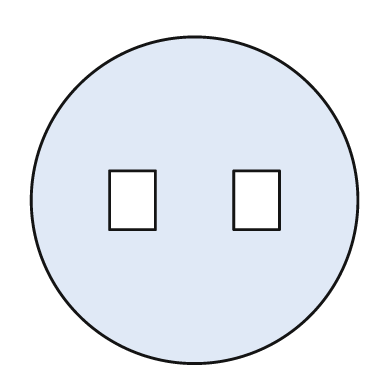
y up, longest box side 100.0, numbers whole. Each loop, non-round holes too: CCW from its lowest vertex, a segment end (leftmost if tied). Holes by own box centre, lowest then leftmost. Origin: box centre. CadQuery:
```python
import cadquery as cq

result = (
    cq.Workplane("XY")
    .moveTo(0.0, 0.0)
    .circle(50.0)
    .moveTo(-26.0, -9.0)
    .lineTo(-12.0, -9.0)
    .lineTo(-12.0, 9.0)
    .lineTo(-26.0, 9.0)
    .close()
    .moveTo(12.0, -9.0)
    .lineTo(26.0, -9.0)
    .lineTo(26.0, 9.0)
    .lineTo(12.0, 9.0)
    .close()
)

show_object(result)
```